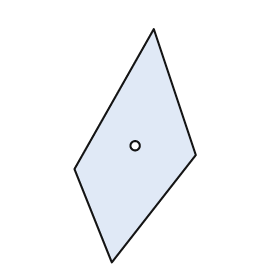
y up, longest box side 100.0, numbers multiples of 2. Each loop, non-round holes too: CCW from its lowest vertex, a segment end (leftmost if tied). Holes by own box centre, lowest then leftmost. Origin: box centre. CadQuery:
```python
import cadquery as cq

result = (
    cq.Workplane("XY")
    .moveTo(-10.0, -50.0)
    .lineTo(26.0, -4.0)
    .lineTo(8.0, 50.0)
    .lineTo(-26.0, -10.0)
    .close()
    .moveTo(0.0, 0.0)
    .circle(2.0)
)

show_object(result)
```